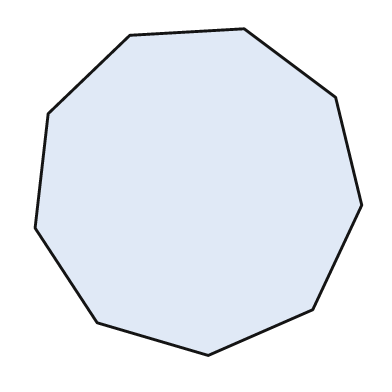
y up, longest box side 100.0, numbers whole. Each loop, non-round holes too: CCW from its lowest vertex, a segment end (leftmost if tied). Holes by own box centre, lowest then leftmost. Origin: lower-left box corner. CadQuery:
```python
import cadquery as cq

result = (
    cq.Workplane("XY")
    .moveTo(53.0, 0.0)
    .lineTo(85.0, 14.0)
    .lineTo(100.0, 46.0)
    .lineTo(92.0, 79.0)
    .lineTo(64.0, 100.0)
    .lineTo(29.0, 98.0)
    .lineTo(4.0, 74.0)
    .lineTo(0.0, 39.0)
    .lineTo(19.0, 10.0)
    .close()
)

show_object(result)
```